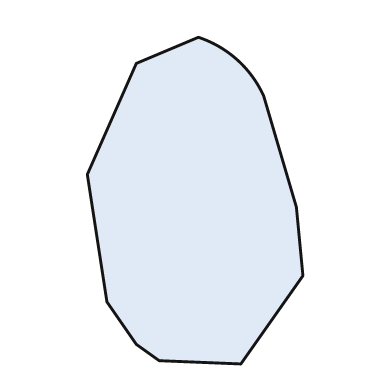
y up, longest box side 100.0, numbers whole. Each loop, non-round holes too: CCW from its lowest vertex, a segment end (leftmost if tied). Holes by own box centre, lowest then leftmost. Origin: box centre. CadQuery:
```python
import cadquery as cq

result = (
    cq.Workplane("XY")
    .moveTo(14.0, -50.0)
    .lineTo(33.0, -23.0)
    .lineTo(31.0, -2.0)
    .lineTo(21.0, 32.0)
    .threePointArc((13.0, 43.0), (1.0, 50.0))
    .lineTo(-18.0, 42.0)
    .lineTo(-33.0, 8.0)
    .lineTo(-27.0, -31.0)
    .lineTo(-18.0, -44.0)
    .lineTo(-11.0, -49.0)
    .close()
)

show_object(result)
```